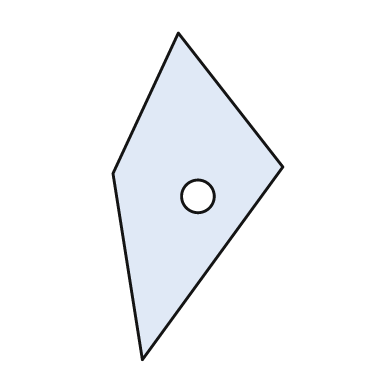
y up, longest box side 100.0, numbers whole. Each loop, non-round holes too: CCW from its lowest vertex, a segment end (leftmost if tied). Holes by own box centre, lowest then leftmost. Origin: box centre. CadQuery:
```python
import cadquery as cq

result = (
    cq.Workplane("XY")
    .moveTo(-17.0, -50.0)
    .lineTo(26.0, 9.0)
    .lineTo(-6.0, 50.0)
    .lineTo(-26.0, 7.0)
    .close()
    .moveTo(0.0, 0.0)
    .circle(5.0)
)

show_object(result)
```